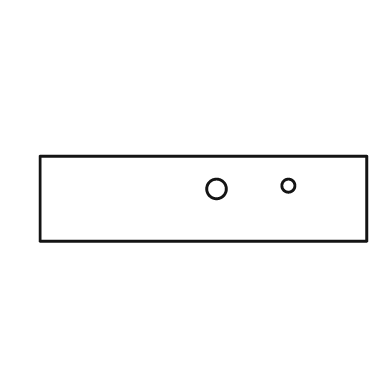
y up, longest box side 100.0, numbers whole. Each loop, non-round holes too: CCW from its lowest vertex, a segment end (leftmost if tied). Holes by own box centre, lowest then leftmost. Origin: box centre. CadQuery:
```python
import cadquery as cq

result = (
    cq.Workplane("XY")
    .moveTo(-50.0, -13.0)
    .lineTo(50.0, -13.0)
    .lineTo(50.0, 13.0)
    .lineTo(-50.0, 13.0)
    .close()
    .moveTo(4.0, 3.0)
    .circle(3.0)
    .moveTo(26.0, 4.0)
    .circle(2.0)
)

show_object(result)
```